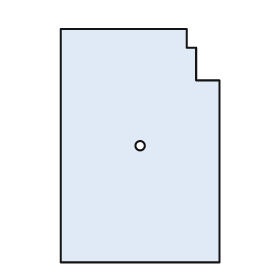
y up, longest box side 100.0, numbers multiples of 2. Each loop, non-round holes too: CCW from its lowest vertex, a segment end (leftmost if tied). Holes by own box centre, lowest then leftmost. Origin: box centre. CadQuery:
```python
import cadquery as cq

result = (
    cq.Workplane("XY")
    .moveTo(-34.0, -50.0)
    .lineTo(34.0, -50.0)
    .lineTo(34.0, 28.0)
    .lineTo(24.0, 28.0)
    .lineTo(24.0, 42.0)
    .lineTo(20.0, 42.0)
    .lineTo(20.0, 50.0)
    .lineTo(-34.0, 50.0)
    .close()
    .moveTo(0.0, 0.0)
    .circle(2.0)
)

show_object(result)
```